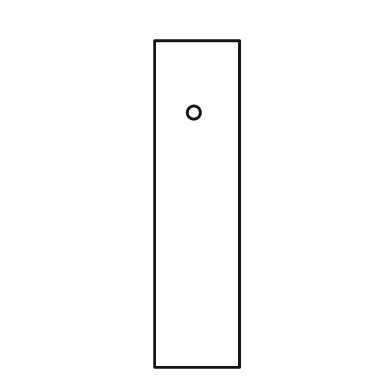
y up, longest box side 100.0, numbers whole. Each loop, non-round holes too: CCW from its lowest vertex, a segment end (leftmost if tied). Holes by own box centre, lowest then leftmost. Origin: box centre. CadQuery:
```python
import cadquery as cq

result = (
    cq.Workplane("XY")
    .moveTo(-13.0, -50.0)
    .lineTo(13.0, -50.0)
    .lineTo(13.0, 50.0)
    .lineTo(-13.0, 50.0)
    .close()
    .moveTo(-1.0, 28.0)
    .circle(2.0)
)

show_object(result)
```